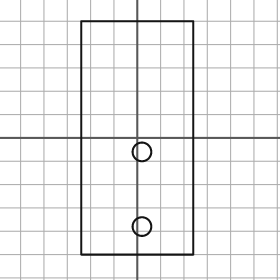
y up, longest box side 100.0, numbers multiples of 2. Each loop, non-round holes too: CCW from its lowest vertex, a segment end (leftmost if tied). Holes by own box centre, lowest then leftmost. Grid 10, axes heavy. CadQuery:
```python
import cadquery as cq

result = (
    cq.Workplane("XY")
    .moveTo(-24.0, -50.0)
    .lineTo(24.0, -50.0)
    .lineTo(24.0, 50.0)
    .lineTo(-24.0, 50.0)
    .close()
    .moveTo(2.0, -38.0)
    .circle(4.0)
    .moveTo(2.0, -6.0)
    .circle(4.0)
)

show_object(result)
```